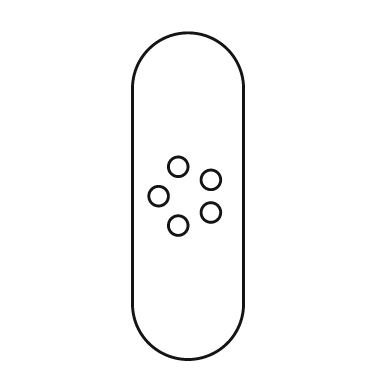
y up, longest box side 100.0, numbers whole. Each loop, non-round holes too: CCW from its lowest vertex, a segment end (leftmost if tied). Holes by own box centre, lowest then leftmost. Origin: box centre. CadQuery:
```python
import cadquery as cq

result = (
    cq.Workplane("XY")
    .moveTo(-17.0, -33.0)
    .threePointArc((0.0, -50.0), (17.0, -33.0))
    .lineTo(17.0, 33.0)
    .threePointArc((0.0, 50.0), (-17.0, 33.0))
    .close()
    .moveTo(-3.0, -9.0)
    .circle(3.0)
    .moveTo(7.0, -5.0)
    .circle(3.0)
    .moveTo(-9.0, 0.0)
    .circle(3.0)
    .moveTo(7.0, 5.0)
    .circle(3.0)
    .moveTo(-3.0, 9.0)
    .circle(3.0)
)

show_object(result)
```